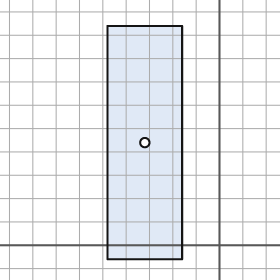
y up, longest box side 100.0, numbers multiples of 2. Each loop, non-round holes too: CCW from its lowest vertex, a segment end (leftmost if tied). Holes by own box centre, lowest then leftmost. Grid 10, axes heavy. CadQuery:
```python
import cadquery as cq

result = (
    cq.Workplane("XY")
    .moveTo(-48.0, -6.0)
    .lineTo(-16.0, -6.0)
    .lineTo(-16.0, 94.0)
    .lineTo(-48.0, 94.0)
    .close()
    .moveTo(-32.0, 44.0)
    .circle(2.0)
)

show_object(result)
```